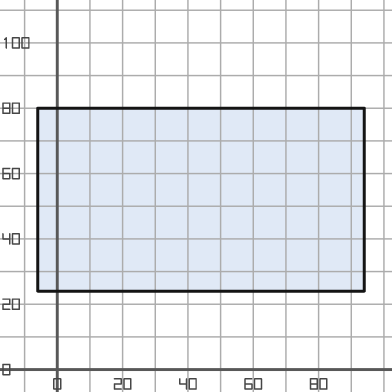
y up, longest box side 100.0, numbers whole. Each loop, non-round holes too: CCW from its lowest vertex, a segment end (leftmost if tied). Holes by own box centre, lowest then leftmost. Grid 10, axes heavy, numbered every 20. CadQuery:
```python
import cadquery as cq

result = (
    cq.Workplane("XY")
    .moveTo(-6.0, 24.0)
    .lineTo(94.0, 24.0)
    .lineTo(94.0, 80.0)
    .lineTo(-6.0, 80.0)
    .close()
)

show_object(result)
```